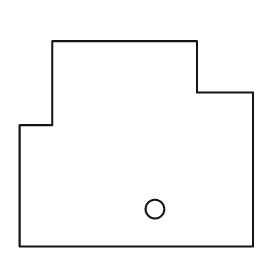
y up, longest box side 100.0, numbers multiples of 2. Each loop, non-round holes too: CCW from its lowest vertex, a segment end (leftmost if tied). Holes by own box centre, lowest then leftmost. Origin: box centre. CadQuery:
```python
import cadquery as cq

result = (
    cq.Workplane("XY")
    .moveTo(-50.0, -44.0)
    .lineTo(50.0, -44.0)
    .lineTo(50.0, 22.0)
    .lineTo(26.0, 22.0)
    .lineTo(26.0, 44.0)
    .lineTo(-36.0, 44.0)
    .lineTo(-36.0, 8.0)
    .lineTo(-50.0, 8.0)
    .close()
    .moveTo(8.0, -28.0)
    .circle(4.0)
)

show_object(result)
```